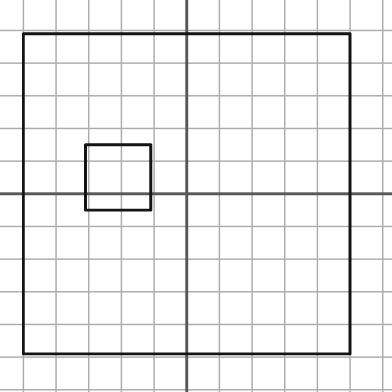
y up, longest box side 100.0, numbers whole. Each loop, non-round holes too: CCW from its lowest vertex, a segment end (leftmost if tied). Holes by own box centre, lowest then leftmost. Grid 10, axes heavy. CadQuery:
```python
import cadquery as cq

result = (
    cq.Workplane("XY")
    .moveTo(-50.0, -49.0)
    .lineTo(50.0, -49.0)
    .lineTo(50.0, 49.0)
    .lineTo(-50.0, 49.0)
    .close()
    .moveTo(-31.0, -5.0)
    .lineTo(-11.0, -5.0)
    .lineTo(-11.0, 15.0)
    .lineTo(-31.0, 15.0)
    .close()
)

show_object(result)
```